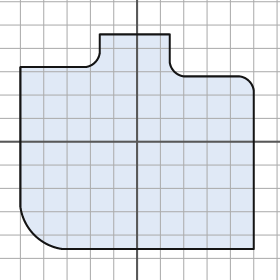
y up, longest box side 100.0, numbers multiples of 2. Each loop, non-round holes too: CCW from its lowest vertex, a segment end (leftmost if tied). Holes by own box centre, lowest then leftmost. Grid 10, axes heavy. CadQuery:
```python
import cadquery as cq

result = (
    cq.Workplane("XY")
    .moveTo(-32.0, -46.0)
    .lineTo(50.0, -46.0)
    .lineTo(50.0, 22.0)
    .threePointArc((48.0, 26.0), (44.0, 28.0))
    .lineTo(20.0, 28.0)
    .threePointArc((16.0, 30.0), (14.0, 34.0))
    .lineTo(14.0, 46.0)
    .lineTo(-16.0, 46.0)
    .lineTo(-16.0, 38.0)
    .threePointArc((-18.0, 34.0), (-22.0, 32.0))
    .lineTo(-50.0, 32.0)
    .lineTo(-50.0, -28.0)
    .threePointArc((-44.0, -40.0), (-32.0, -46.0))
    .close()
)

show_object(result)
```